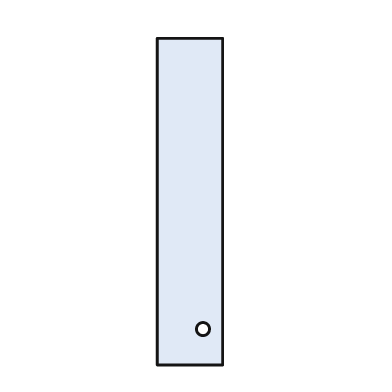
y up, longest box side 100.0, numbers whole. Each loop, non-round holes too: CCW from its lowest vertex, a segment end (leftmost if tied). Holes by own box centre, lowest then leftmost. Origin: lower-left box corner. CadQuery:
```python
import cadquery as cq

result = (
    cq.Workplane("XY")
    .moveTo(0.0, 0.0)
    .lineTo(20.0, 0.0)
    .lineTo(20.0, 100.0)
    .lineTo(0.0, 100.0)
    .close()
    .moveTo(14.0, 11.0)
    .circle(2.0)
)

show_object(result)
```